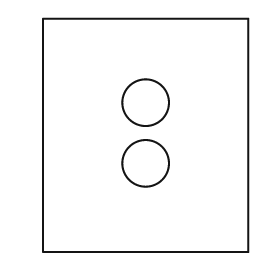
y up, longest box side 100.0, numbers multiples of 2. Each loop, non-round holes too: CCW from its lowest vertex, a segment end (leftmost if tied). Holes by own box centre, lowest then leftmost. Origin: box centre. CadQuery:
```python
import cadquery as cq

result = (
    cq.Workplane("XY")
    .moveTo(-44.0, -50.0)
    .lineTo(44.0, -50.0)
    .lineTo(44.0, 50.0)
    .lineTo(-44.0, 50.0)
    .close()
    .moveTo(0.0, -12.0)
    .circle(10.0)
    .moveTo(0.0, 14.0)
    .circle(10.0)
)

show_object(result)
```